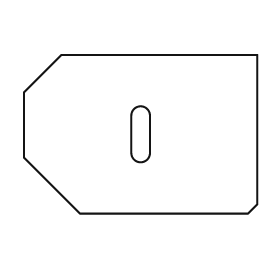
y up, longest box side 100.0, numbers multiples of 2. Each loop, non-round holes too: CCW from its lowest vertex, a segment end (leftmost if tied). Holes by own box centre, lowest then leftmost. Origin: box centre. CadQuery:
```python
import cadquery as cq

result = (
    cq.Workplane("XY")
    .moveTo(-26.0, -34.0)
    .lineTo(46.0, -34.0)
    .lineTo(50.0, -30.0)
    .lineTo(50.0, 34.0)
    .lineTo(-34.0, 34.0)
    .lineTo(-50.0, 18.0)
    .lineTo(-50.0, -10.0)
    .close()
    .moveTo(-4.0, -8.0)
    .threePointArc((0.0, -12.0), (4.0, -8.0))
    .lineTo(4.0, 8.0)
    .threePointArc((0.0, 12.0), (-4.0, 8.0))
    .close()
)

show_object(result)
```